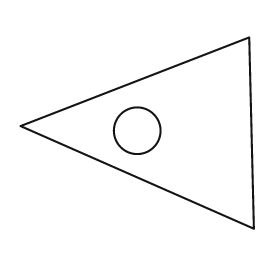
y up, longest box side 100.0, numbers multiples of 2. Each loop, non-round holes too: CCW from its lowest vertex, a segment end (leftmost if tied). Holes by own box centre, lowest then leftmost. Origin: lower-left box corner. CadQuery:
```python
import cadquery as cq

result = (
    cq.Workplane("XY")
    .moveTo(100.0, 0.0)
    .lineTo(98.0, 82.0)
    .lineTo(0.0, 44.0)
    .close()
    .moveTo(50.0, 42.0)
    .circle(10.0)
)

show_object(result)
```